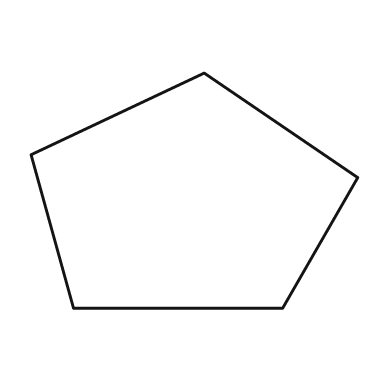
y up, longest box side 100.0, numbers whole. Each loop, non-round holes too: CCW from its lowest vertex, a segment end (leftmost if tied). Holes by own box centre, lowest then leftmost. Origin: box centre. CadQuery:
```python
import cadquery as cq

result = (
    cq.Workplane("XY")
    .moveTo(-37.0, -36.0)
    .lineTo(27.0, -36.0)
    .lineTo(50.0, 4.0)
    .lineTo(3.0, 36.0)
    .lineTo(-50.0, 11.0)
    .close()
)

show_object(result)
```